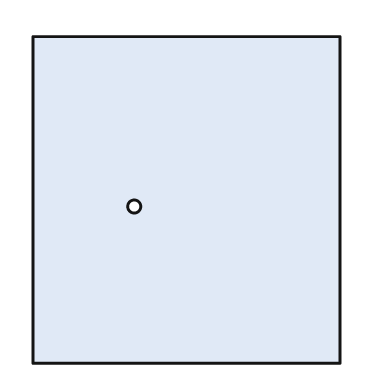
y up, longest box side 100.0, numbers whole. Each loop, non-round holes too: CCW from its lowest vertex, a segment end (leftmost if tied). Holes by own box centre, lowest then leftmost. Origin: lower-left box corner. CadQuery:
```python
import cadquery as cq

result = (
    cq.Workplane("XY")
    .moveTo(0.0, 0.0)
    .lineTo(94.0, 0.0)
    .lineTo(94.0, 100.0)
    .lineTo(0.0, 100.0)
    .close()
    .moveTo(31.0, 48.0)
    .circle(2.0)
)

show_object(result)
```